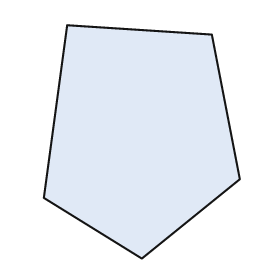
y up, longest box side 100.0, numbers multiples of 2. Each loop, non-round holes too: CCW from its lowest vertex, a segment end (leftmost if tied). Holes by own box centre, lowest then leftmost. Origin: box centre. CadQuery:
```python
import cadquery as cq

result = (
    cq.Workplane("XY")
    .moveTo(0.0, -50.0)
    .lineTo(42.0, -16.0)
    .lineTo(30.0, 46.0)
    .lineTo(-32.0, 50.0)
    .lineTo(-42.0, -24.0)
    .close()
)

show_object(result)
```